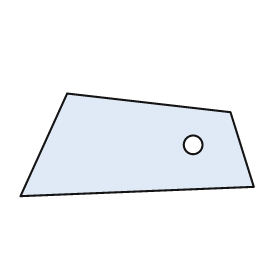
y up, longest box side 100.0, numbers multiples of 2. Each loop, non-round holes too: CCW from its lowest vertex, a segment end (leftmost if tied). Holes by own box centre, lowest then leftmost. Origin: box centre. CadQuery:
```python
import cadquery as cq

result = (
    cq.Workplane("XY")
    .moveTo(-50.0, -22.0)
    .lineTo(50.0, -18.0)
    .lineTo(40.0, 14.0)
    .lineTo(-30.0, 22.0)
    .close()
    .moveTo(24.0, 0.0)
    .circle(4.0)
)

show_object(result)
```